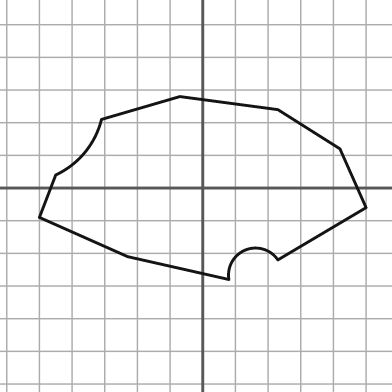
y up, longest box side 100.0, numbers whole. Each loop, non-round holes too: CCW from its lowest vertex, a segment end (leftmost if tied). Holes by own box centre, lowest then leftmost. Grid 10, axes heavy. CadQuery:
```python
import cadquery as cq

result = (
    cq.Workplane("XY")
    .moveTo(8.0, -28.0)
    .threePointArc((13.0, -19.0), (23.0, -22.0))
    .lineTo(50.0, -6.0)
    .lineTo(42.0, 12.0)
    .lineTo(23.0, 24.0)
    .lineTo(-7.0, 28.0)
    .lineTo(-31.0, 21.0)
    .threePointArc((-36.0, 11.0), (-45.0, 4.0))
    .lineTo(-50.0, -9.0)
    .lineTo(-23.0, -21.0)
    .close()
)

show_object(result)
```